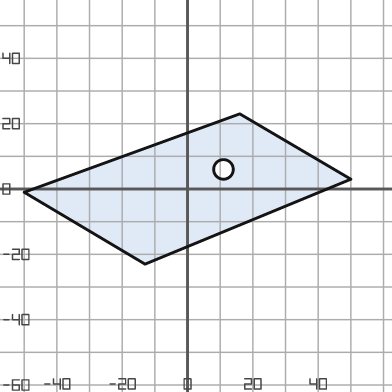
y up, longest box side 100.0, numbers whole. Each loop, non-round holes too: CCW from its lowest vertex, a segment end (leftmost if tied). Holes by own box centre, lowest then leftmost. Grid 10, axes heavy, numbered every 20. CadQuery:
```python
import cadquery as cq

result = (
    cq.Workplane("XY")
    .moveTo(-13.0, -23.0)
    .lineTo(50.0, 3.0)
    .lineTo(16.0, 23.0)
    .lineTo(-50.0, -1.0)
    .close()
    .moveTo(11.0, 6.0)
    .circle(3.0)
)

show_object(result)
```